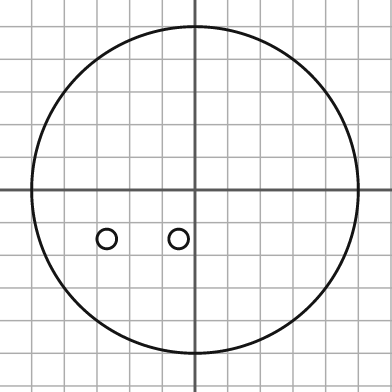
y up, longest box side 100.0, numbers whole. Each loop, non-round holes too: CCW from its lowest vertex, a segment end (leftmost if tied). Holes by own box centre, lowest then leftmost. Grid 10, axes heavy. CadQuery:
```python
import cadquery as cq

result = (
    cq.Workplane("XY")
    .moveTo(0.0, 0.0)
    .circle(50.0)
    .moveTo(-27.0, -15.0)
    .circle(3.0)
    .moveTo(-5.0, -15.0)
    .circle(3.0)
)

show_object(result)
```